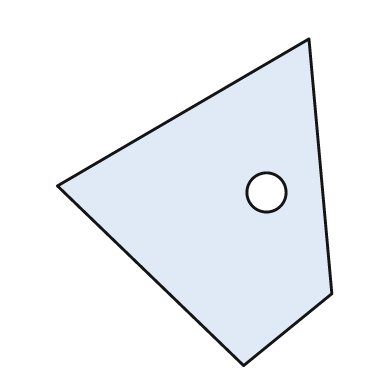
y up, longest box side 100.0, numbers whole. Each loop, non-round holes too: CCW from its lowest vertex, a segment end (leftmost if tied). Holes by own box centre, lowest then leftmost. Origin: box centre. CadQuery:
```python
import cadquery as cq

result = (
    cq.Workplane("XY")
    .moveTo(15.0, -50.0)
    .lineTo(42.0, -28.0)
    .lineTo(35.0, 50.0)
    .lineTo(-42.0, 5.0)
    .close()
    .moveTo(22.0, 3.0)
    .circle(6.0)
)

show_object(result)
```